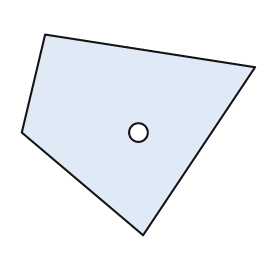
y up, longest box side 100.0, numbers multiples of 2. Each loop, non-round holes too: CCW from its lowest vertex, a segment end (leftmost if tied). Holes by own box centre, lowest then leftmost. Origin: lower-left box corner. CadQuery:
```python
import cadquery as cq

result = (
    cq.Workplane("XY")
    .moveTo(52.0, 0.0)
    .lineTo(100.0, 72.0)
    .lineTo(10.0, 86.0)
    .lineTo(0.0, 44.0)
    .close()
    .moveTo(50.0, 44.0)
    .circle(4.0)
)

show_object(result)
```